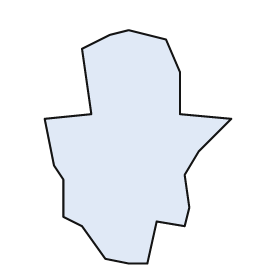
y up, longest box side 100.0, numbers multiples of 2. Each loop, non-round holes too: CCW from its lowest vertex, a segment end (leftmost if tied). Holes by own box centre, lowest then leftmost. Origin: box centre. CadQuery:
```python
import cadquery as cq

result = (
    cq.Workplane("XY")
    .moveTo(-4.0, -50.0)
    .lineTo(4.0, -50.0)
    .lineTo(8.0, -32.0)
    .lineTo(20.0, -34.0)
    .lineTo(22.0, -26.0)
    .lineTo(20.0, -12.0)
    .lineTo(26.0, -2.0)
    .lineTo(40.0, 12.0)
    .lineTo(18.0, 14.0)
    .lineTo(18.0, 32.0)
    .lineTo(12.0, 46.0)
    .lineTo(-4.0, 50.0)
    .lineTo(-12.0, 48.0)
    .lineTo(-24.0, 42.0)
    .lineTo(-20.0, 14.0)
    .lineTo(-40.0, 12.0)
    .lineTo(-36.0, -8.0)
    .lineTo(-32.0, -14.0)
    .lineTo(-32.0, -30.0)
    .lineTo(-24.0, -34.0)
    .lineTo(-14.0, -48.0)
    .close()
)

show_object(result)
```